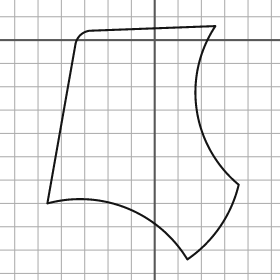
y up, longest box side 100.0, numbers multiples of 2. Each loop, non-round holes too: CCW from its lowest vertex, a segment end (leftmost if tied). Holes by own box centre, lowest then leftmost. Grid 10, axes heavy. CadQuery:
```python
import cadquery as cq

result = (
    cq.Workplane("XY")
    .moveTo(14.0, -94.0)
    .threePointArc((28.0, -80.0), (36.0, -62.0))
    .threePointArc((18.0, -30.0), (26.0, 6.0))
    .lineTo(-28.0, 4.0)
    .threePointArc((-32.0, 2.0), (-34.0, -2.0))
    .lineTo(-46.0, -70.0)
    .threePointArc((-12.0, -72.0), (14.0, -94.0))
    .close()
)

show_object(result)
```